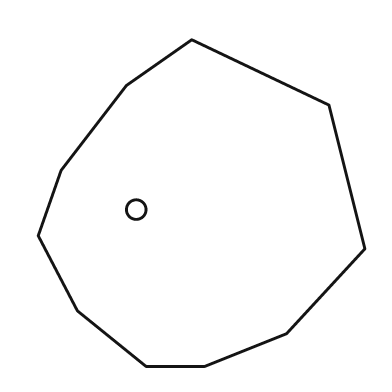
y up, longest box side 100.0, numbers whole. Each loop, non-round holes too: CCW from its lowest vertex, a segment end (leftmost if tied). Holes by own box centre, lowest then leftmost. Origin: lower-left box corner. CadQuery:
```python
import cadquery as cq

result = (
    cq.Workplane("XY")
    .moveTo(33.0, 0.0)
    .lineTo(51.0, 0.0)
    .lineTo(76.0, 10.0)
    .lineTo(100.0, 36.0)
    .lineTo(89.0, 80.0)
    .lineTo(47.0, 100.0)
    .lineTo(27.0, 86.0)
    .lineTo(7.0, 60.0)
    .lineTo(0.0, 40.0)
    .lineTo(12.0, 17.0)
    .close()
    .moveTo(30.0, 48.0)
    .circle(3.0)
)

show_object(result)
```